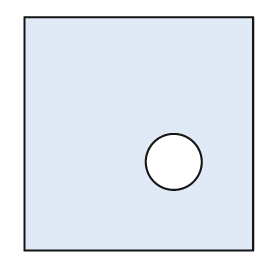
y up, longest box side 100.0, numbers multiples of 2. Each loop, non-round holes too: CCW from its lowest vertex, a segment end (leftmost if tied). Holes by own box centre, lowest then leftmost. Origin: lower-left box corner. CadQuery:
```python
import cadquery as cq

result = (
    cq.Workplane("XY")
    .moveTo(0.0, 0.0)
    .lineTo(98.0, 0.0)
    .lineTo(98.0, 100.0)
    .lineTo(0.0, 100.0)
    .close()
    .moveTo(64.0, 38.0)
    .circle(12.0)
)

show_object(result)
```